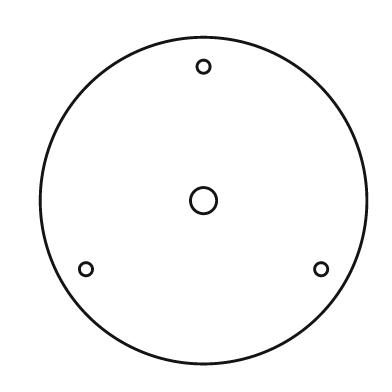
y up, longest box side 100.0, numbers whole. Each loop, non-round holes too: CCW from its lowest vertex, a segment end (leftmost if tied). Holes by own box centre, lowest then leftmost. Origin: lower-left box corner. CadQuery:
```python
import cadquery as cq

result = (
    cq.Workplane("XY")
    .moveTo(50.0, 50.0)
    .circle(50.0)
    .moveTo(14.0, 29.0)
    .circle(2.0)
    .moveTo(86.0, 29.0)
    .circle(2.0)
    .moveTo(50.0, 50.0)
    .circle(4.0)
    .moveTo(50.0, 91.0)
    .circle(2.0)
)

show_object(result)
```